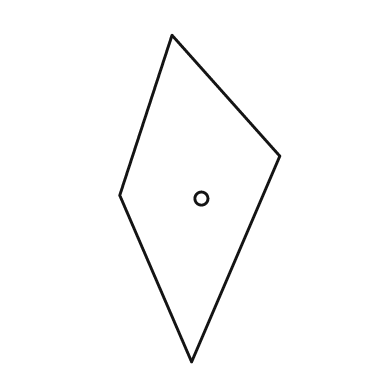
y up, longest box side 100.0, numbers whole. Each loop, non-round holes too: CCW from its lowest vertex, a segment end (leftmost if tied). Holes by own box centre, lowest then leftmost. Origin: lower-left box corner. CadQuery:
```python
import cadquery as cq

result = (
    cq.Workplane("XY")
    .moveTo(22.0, 0.0)
    .lineTo(49.0, 63.0)
    .lineTo(16.0, 100.0)
    .lineTo(0.0, 51.0)
    .close()
    .moveTo(25.0, 50.0)
    .circle(2.0)
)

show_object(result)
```